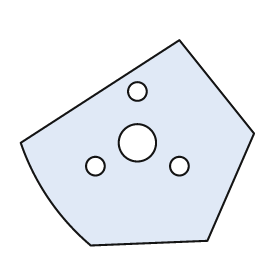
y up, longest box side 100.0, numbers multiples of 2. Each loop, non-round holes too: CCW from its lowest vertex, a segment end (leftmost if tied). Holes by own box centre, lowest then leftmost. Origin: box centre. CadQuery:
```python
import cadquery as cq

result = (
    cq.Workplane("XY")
    .moveTo(-20.0, -44.0)
    .lineTo(30.0, -42.0)
    .lineTo(50.0, 4.0)
    .lineTo(18.0, 44.0)
    .lineTo(-50.0, 0.0)
    .threePointArc((-38.0, -24.0), (-20.0, -44.0))
    .close()
    .moveTo(-18.0, -10.0)
    .circle(4.0)
    .moveTo(18.0, -10.0)
    .circle(4.0)
    .moveTo(0.0, 0.0)
    .circle(8.0)
    .moveTo(0.0, 22.0)
    .circle(4.0)
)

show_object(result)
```